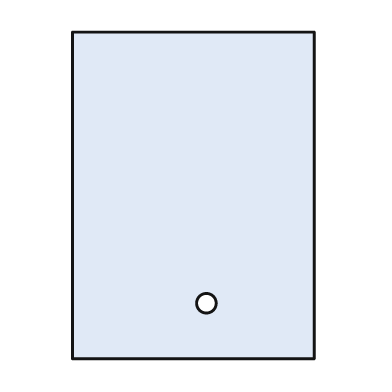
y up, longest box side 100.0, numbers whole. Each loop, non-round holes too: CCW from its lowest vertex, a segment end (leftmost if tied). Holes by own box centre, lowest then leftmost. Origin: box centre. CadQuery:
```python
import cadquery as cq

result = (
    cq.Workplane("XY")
    .moveTo(-37.0, -50.0)
    .lineTo(37.0, -50.0)
    .lineTo(37.0, 50.0)
    .lineTo(-37.0, 50.0)
    .close()
    .moveTo(4.0, -33.0)
    .circle(3.0)
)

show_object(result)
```